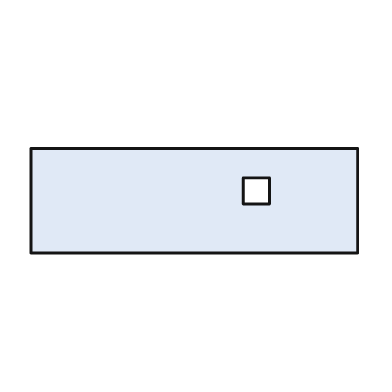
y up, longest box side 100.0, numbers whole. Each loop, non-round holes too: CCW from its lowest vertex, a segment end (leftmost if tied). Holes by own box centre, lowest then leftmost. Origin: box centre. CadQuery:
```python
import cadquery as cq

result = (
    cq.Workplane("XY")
    .moveTo(-50.0, -16.0)
    .lineTo(50.0, -16.0)
    .lineTo(50.0, 16.0)
    .lineTo(-50.0, 16.0)
    .close()
    .moveTo(15.0, -1.0)
    .lineTo(23.0, -1.0)
    .lineTo(23.0, 7.0)
    .lineTo(15.0, 7.0)
    .close()
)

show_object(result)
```